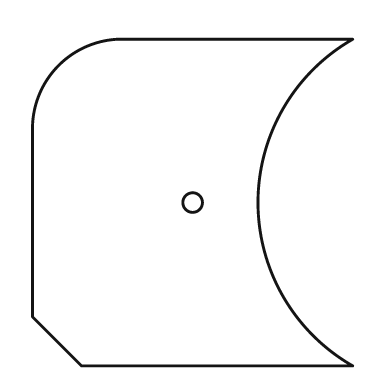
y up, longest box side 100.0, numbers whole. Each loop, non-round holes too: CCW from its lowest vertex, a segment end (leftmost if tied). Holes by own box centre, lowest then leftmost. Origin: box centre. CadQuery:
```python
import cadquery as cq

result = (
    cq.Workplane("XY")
    .moveTo(-34.0, -50.0)
    .lineTo(49.0, -50.0)
    .threePointArc((20.0, 0.0), (49.0, 50.0))
    .lineTo(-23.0, 50.0)
    .threePointArc((-41.0, 42.0), (-49.0, 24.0))
    .lineTo(-49.0, -35.0)
    .close()
    .moveTo(0.0, 0.0)
    .circle(3.0)
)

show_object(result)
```